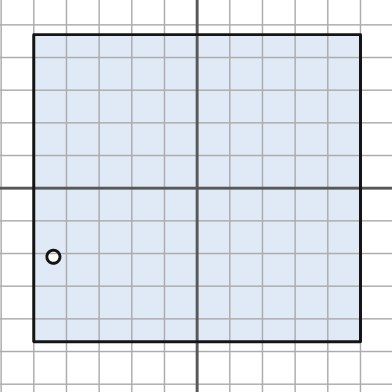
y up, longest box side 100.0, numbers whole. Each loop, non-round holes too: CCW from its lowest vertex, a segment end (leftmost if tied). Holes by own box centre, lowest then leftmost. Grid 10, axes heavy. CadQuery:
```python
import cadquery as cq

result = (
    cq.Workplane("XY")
    .moveTo(-50.0, -47.0)
    .lineTo(50.0, -47.0)
    .lineTo(50.0, 47.0)
    .lineTo(-50.0, 47.0)
    .close()
    .moveTo(-44.0, -21.0)
    .circle(2.0)
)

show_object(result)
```